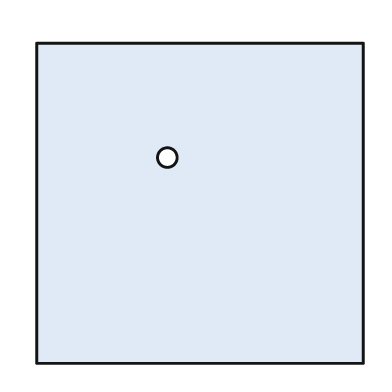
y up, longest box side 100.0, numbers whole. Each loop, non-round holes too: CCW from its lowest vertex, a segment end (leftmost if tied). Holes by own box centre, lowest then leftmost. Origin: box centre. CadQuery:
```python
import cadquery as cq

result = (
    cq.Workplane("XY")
    .moveTo(-50.0, -49.0)
    .lineTo(50.0, -49.0)
    .lineTo(50.0, 49.0)
    .lineTo(-50.0, 49.0)
    .close()
    .moveTo(-10.0, 14.0)
    .circle(3.0)
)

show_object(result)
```